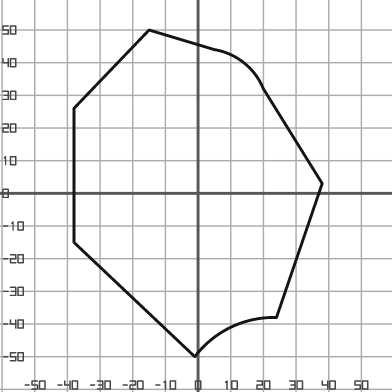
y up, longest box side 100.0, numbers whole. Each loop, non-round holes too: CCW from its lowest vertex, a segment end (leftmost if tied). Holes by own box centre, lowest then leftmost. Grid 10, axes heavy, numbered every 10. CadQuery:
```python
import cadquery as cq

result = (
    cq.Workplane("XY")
    .moveTo(-1.0, -50.0)
    .threePointArc((10.0, -41.0), (24.0, -38.0))
    .lineTo(38.0, 3.0)
    .lineTo(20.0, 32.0)
    .threePointArc((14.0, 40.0), (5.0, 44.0))
    .lineTo(-15.0, 50.0)
    .lineTo(-38.0, 26.0)
    .lineTo(-38.0, -15.0)
    .close()
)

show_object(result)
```